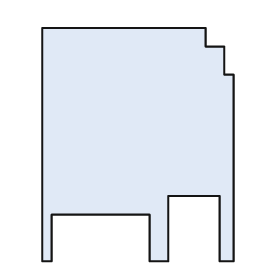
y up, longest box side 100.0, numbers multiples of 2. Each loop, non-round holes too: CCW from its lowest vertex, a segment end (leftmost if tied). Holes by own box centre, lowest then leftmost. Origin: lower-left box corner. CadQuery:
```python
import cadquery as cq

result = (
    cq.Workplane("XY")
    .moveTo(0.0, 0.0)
    .lineTo(4.0, 0.0)
    .lineTo(4.0, 20.0)
    .lineTo(46.0, 20.0)
    .lineTo(46.0, 0.0)
    .lineTo(54.0, 0.0)
    .lineTo(54.0, 28.0)
    .lineTo(76.0, 28.0)
    .lineTo(76.0, 0.0)
    .lineTo(82.0, 0.0)
    .lineTo(82.0, 80.0)
    .lineTo(78.0, 80.0)
    .lineTo(78.0, 92.0)
    .lineTo(70.0, 92.0)
    .lineTo(70.0, 100.0)
    .lineTo(0.0, 100.0)
    .close()
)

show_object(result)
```